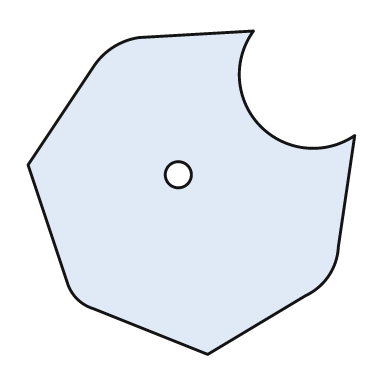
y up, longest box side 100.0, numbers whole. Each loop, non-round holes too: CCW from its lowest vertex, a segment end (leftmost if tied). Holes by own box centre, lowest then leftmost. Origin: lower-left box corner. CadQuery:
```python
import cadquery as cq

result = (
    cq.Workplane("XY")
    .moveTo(55.0, 0.0)
    .lineTo(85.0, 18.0)
    .threePointArc((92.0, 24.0), (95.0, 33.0))
    .lineTo(100.0, 67.0)
    .threePointArc((71.0, 70.0), (69.0, 99.0))
    .lineTo(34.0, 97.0)
    .threePointArc((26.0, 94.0), (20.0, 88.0))
    .lineTo(0.0, 58.0)
    .lineTo(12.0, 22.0)
    .threePointArc((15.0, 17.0), (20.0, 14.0))
    .close()
    .moveTo(46.0, 55.0)
    .circle(4.0)
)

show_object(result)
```